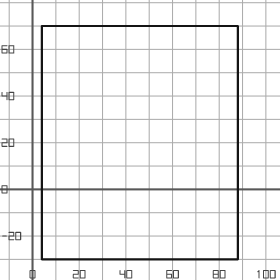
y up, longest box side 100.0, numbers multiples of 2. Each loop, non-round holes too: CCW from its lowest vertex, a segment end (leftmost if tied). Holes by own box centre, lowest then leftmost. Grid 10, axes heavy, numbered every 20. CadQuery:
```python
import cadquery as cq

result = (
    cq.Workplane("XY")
    .moveTo(4.0, -30.0)
    .lineTo(88.0, -30.0)
    .lineTo(88.0, 70.0)
    .lineTo(4.0, 70.0)
    .close()
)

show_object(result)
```